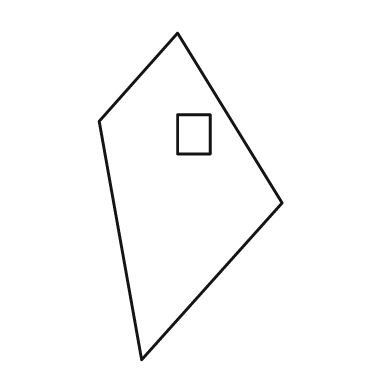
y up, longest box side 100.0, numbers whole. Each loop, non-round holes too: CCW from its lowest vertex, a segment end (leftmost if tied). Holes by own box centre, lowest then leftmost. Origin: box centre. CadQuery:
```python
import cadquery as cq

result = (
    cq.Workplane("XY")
    .moveTo(-15.0, -50.0)
    .lineTo(28.0, -2.0)
    .lineTo(-4.0, 50.0)
    .lineTo(-28.0, 23.0)
    .close()
    .moveTo(-4.0, 13.0)
    .lineTo(6.0, 13.0)
    .lineTo(6.0, 25.0)
    .lineTo(-4.0, 25.0)
    .close()
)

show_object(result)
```